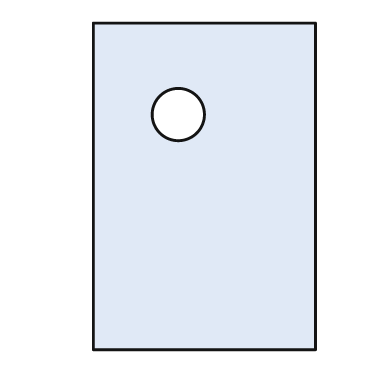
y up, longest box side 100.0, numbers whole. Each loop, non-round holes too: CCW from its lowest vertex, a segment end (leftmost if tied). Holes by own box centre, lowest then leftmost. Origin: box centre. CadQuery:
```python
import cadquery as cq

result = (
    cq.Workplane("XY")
    .moveTo(-34.0, -50.0)
    .lineTo(34.0, -50.0)
    .lineTo(34.0, 50.0)
    .lineTo(-34.0, 50.0)
    .close()
    .moveTo(-8.0, 22.0)
    .circle(8.0)
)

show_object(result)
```